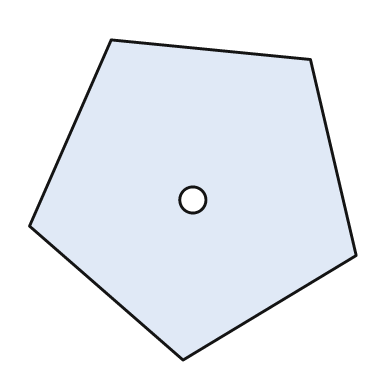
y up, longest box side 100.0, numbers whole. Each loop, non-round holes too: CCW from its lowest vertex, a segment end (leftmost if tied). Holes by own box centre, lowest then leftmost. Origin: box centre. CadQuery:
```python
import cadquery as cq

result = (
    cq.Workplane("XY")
    .moveTo(-3.0, -49.0)
    .lineTo(50.0, -17.0)
    .lineTo(36.0, 43.0)
    .lineTo(-25.0, 49.0)
    .lineTo(-50.0, -8.0)
    .close()
    .moveTo(0.0, 0.0)
    .circle(4.0)
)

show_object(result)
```